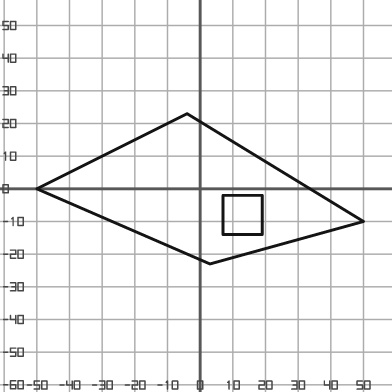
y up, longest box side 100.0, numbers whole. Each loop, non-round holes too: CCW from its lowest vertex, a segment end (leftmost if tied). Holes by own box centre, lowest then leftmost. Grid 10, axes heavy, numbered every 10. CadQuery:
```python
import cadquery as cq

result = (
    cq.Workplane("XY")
    .moveTo(3.0, -23.0)
    .lineTo(50.0, -10.0)
    .lineTo(-4.0, 23.0)
    .lineTo(-50.0, 0.0)
    .close()
    .moveTo(7.0, -14.0)
    .lineTo(19.0, -14.0)
    .lineTo(19.0, -2.0)
    .lineTo(7.0, -2.0)
    .close()
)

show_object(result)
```